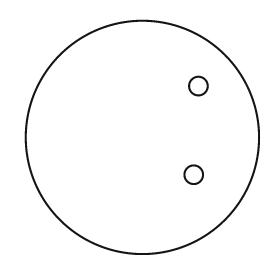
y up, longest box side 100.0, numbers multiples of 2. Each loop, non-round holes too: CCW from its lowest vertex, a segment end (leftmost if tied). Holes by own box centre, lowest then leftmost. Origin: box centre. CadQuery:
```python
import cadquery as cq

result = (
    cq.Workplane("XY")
    .moveTo(0.0, 0.0)
    .circle(50.0)
    .moveTo(22.0, -16.0)
    .circle(4.0)
    .moveTo(24.0, 22.0)
    .circle(4.0)
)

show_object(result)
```